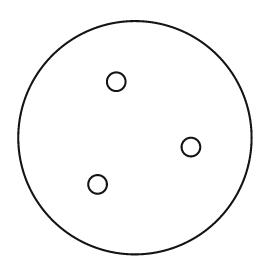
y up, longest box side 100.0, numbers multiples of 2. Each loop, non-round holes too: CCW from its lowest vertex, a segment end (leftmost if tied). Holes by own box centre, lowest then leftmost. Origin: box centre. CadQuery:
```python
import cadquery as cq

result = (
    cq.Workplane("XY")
    .moveTo(0.0, 0.0)
    .circle(50.0)
    .moveTo(-16.0, -20.0)
    .circle(4.0)
    .moveTo(24.0, -4.0)
    .circle(4.0)
    .moveTo(-8.0, 24.0)
    .circle(4.0)
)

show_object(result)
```